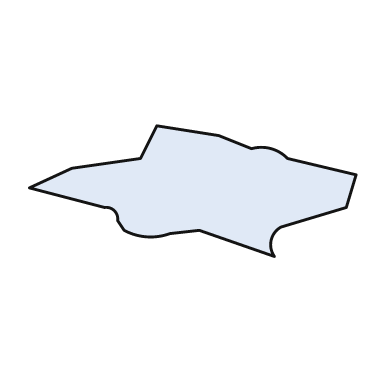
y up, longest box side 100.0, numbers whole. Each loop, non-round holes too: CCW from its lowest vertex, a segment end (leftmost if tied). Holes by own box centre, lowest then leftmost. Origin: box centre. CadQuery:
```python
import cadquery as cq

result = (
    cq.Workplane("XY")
    .moveTo(25.0, -20.0)
    .threePointArc((24.0, -15.0), (27.0, -11.0))
    .lineTo(47.0, -5.0)
    .lineTo(50.0, 5.0)
    .lineTo(29.0, 10.0)
    .threePointArc((24.0, 13.0), (18.0, 13.0))
    .lineTo(8.0, 17.0)
    .lineTo(-11.0, 20.0)
    .lineTo(-16.0, 10.0)
    .lineTo(-37.0, 7.0)
    .lineTo(-50.0, 1.0)
    .lineTo(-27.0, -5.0)
    .threePointArc((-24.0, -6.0), (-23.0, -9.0))
    .lineTo(-21.0, -12.0)
    .threePointArc((-14.0, -14.0), (-7.0, -13.0))
    .lineTo(2.0, -12.0)
    .close()
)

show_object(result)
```